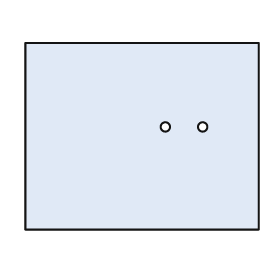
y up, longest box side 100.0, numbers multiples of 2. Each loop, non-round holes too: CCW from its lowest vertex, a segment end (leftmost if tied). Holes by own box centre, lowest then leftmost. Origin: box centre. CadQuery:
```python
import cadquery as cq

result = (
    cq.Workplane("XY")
    .moveTo(-50.0, -40.0)
    .lineTo(50.0, -40.0)
    .lineTo(50.0, 40.0)
    .lineTo(-50.0, 40.0)
    .close()
    .moveTo(10.0, 4.0)
    .circle(2.0)
    .moveTo(26.0, 4.0)
    .circle(2.0)
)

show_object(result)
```